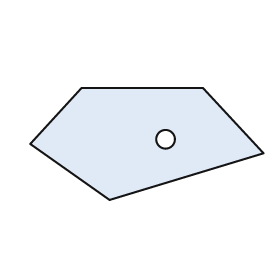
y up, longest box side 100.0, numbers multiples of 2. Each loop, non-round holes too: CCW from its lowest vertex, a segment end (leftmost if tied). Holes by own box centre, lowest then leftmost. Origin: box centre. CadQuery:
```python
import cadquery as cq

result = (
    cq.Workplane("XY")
    .moveTo(-16.0, -24.0)
    .lineTo(50.0, -4.0)
    .lineTo(24.0, 24.0)
    .lineTo(-28.0, 24.0)
    .lineTo(-50.0, 0.0)
    .close()
    .moveTo(8.0, 2.0)
    .circle(4.0)
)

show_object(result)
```